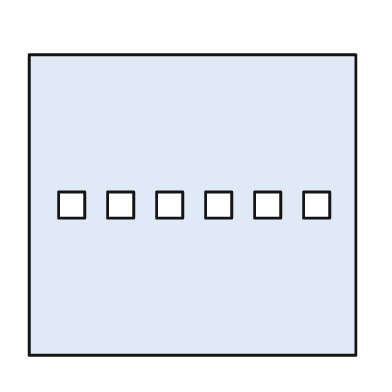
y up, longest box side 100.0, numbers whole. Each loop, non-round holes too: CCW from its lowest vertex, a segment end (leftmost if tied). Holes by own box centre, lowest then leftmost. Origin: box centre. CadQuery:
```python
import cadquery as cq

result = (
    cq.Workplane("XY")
    .moveTo(-50.0, -46.0)
    .lineTo(50.0, -46.0)
    .lineTo(50.0, 46.0)
    .lineTo(-50.0, 46.0)
    .close()
    .moveTo(-41.0, -4.0)
    .lineTo(-33.0, -4.0)
    .lineTo(-33.0, 4.0)
    .lineTo(-41.0, 4.0)
    .close()
    .moveTo(-26.0, -4.0)
    .lineTo(-18.0, -4.0)
    .lineTo(-18.0, 4.0)
    .lineTo(-26.0, 4.0)
    .close()
    .moveTo(-11.0, -4.0)
    .lineTo(-3.0, -4.0)
    .lineTo(-3.0, 4.0)
    .lineTo(-11.0, 4.0)
    .close()
    .moveTo(4.0, -4.0)
    .lineTo(12.0, -4.0)
    .lineTo(12.0, 4.0)
    .lineTo(4.0, 4.0)
    .close()
    .moveTo(19.0, -4.0)
    .lineTo(27.0, -4.0)
    .lineTo(27.0, 4.0)
    .lineTo(19.0, 4.0)
    .close()
    .moveTo(34.0, -4.0)
    .lineTo(42.0, -4.0)
    .lineTo(42.0, 4.0)
    .lineTo(34.0, 4.0)
    .close()
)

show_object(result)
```